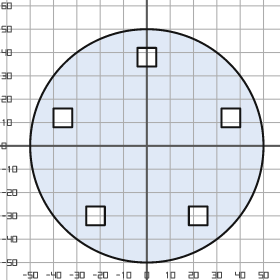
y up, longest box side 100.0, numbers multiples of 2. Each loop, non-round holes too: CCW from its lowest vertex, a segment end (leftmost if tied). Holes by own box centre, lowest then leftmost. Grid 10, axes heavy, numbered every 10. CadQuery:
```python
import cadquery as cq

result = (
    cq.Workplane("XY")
    .moveTo(0.0, 0.0)
    .circle(50.0)
    .moveTo(-26.0, -34.0)
    .lineTo(-18.0, -34.0)
    .lineTo(-18.0, -26.0)
    .lineTo(-26.0, -26.0)
    .close()
    .moveTo(18.0, -34.0)
    .lineTo(26.0, -34.0)
    .lineTo(26.0, -26.0)
    .lineTo(18.0, -26.0)
    .close()
    .moveTo(-40.0, 8.0)
    .lineTo(-32.0, 8.0)
    .lineTo(-32.0, 16.0)
    .lineTo(-40.0, 16.0)
    .close()
    .moveTo(32.0, 8.0)
    .lineTo(40.0, 8.0)
    .lineTo(40.0, 16.0)
    .lineTo(32.0, 16.0)
    .close()
    .moveTo(-4.0, 34.0)
    .lineTo(4.0, 34.0)
    .lineTo(4.0, 42.0)
    .lineTo(-4.0, 42.0)
    .close()
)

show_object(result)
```